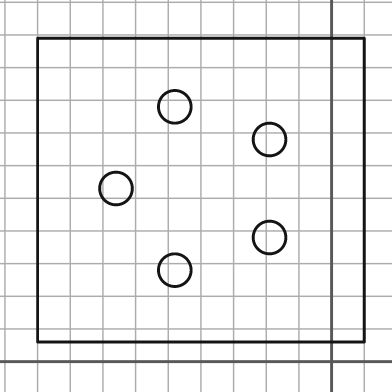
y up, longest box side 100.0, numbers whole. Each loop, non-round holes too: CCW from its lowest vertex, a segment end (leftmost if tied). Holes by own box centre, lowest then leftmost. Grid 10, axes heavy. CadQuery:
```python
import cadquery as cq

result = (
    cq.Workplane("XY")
    .moveTo(-90.0, 6.0)
    .lineTo(10.0, 6.0)
    .lineTo(10.0, 99.0)
    .lineTo(-90.0, 99.0)
    .close()
    .moveTo(-48.0, 28.0)
    .circle(5.0)
    .moveTo(-19.0, 38.0)
    .circle(5.0)
    .moveTo(-66.0, 53.0)
    .circle(5.0)
    .moveTo(-19.0, 68.0)
    .circle(5.0)
    .moveTo(-48.0, 78.0)
    .circle(5.0)
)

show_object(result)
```